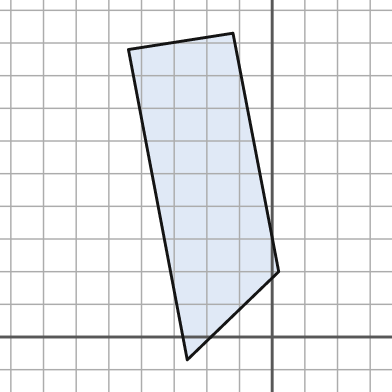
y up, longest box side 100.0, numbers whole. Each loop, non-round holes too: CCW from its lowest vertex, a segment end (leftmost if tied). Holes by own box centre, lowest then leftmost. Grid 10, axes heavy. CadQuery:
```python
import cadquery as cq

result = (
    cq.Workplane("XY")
    .moveTo(-26.0, -7.0)
    .lineTo(2.0, 20.0)
    .lineTo(-12.0, 93.0)
    .lineTo(-44.0, 88.0)
    .close()
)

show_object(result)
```